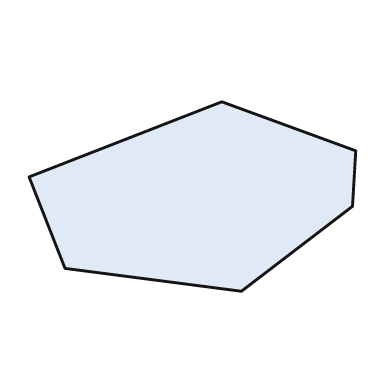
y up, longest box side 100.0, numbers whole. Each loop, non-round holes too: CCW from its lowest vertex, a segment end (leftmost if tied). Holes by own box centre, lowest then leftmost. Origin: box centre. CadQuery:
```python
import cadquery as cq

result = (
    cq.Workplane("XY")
    .moveTo(15.0, -29.0)
    .lineTo(49.0, -3.0)
    .lineTo(50.0, 14.0)
    .lineTo(9.0, 29.0)
    .lineTo(-50.0, 6.0)
    .lineTo(-39.0, -22.0)
    .close()
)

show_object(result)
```